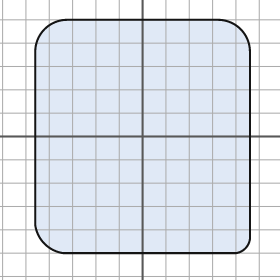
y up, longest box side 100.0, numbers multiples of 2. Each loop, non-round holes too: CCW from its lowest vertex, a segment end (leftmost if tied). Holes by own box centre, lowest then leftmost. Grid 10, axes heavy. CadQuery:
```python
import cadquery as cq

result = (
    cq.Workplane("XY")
    .moveTo(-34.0, -50.0)
    .lineTo(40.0, -50.0)
    .threePointArc((44.0, -48.0), (46.0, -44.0))
    .lineTo(46.0, 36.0)
    .threePointArc((42.0, 46.0), (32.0, 50.0))
    .lineTo(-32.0, 50.0)
    .threePointArc((-42.0, 46.0), (-46.0, 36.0))
    .lineTo(-46.0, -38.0)
    .threePointArc((-42.0, -46.0), (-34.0, -50.0))
    .close()
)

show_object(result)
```